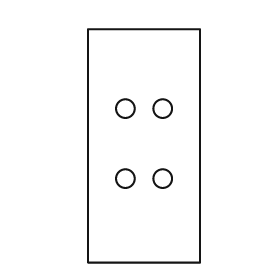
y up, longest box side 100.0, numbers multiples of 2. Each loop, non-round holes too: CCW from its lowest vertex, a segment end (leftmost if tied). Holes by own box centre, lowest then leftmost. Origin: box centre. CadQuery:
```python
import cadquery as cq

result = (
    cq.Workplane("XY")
    .moveTo(-24.0, -50.0)
    .lineTo(24.0, -50.0)
    .lineTo(24.0, 50.0)
    .lineTo(-24.0, 50.0)
    .close()
    .moveTo(-8.0, -14.0)
    .circle(4.0)
    .moveTo(8.0, -14.0)
    .circle(4.0)
    .moveTo(-8.0, 16.0)
    .circle(4.0)
    .moveTo(8.0, 16.0)
    .circle(4.0)
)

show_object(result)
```